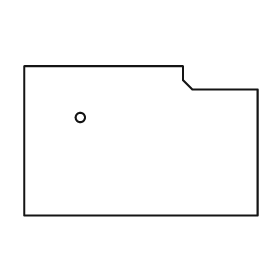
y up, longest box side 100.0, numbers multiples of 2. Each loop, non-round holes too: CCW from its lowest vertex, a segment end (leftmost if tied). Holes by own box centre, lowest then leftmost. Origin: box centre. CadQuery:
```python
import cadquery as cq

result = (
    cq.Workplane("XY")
    .moveTo(-50.0, -32.0)
    .lineTo(50.0, -32.0)
    .lineTo(50.0, 22.0)
    .lineTo(22.0, 22.0)
    .lineTo(18.0, 26.0)
    .lineTo(18.0, 32.0)
    .lineTo(-50.0, 32.0)
    .close()
    .moveTo(-26.0, 10.0)
    .circle(2.0)
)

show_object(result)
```